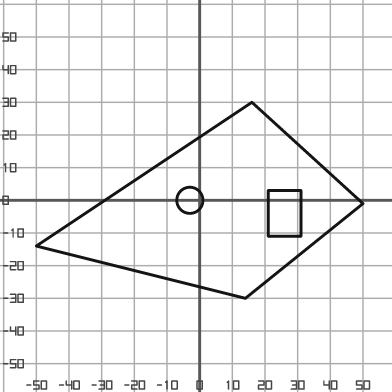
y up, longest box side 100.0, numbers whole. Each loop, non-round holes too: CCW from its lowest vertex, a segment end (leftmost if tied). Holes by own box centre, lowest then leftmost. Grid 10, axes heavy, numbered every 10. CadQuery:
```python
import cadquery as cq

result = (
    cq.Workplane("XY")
    .moveTo(14.0, -30.0)
    .lineTo(50.0, -1.0)
    .lineTo(16.0, 30.0)
    .lineTo(-50.0, -14.0)
    .close()
    .moveTo(21.0, -11.0)
    .lineTo(31.0, -11.0)
    .lineTo(31.0, 3.0)
    .lineTo(21.0, 3.0)
    .close()
    .moveTo(-3.0, 0.0)
    .circle(4.0)
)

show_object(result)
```